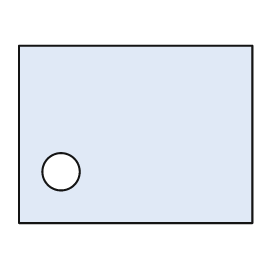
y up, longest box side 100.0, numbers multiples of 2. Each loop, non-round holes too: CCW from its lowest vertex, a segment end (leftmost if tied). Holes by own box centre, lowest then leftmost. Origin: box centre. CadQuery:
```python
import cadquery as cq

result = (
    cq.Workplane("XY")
    .moveTo(-50.0, -38.0)
    .lineTo(50.0, -38.0)
    .lineTo(50.0, 38.0)
    .lineTo(-50.0, 38.0)
    .close()
    .moveTo(-32.0, -16.0)
    .circle(8.0)
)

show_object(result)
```